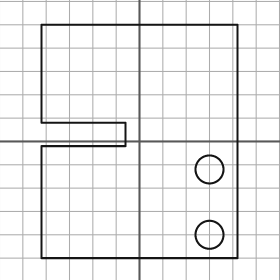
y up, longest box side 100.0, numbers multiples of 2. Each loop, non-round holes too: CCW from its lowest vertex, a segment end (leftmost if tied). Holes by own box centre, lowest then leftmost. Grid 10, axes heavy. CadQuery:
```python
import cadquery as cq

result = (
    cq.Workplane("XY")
    .moveTo(-42.0, -50.0)
    .lineTo(42.0, -50.0)
    .lineTo(42.0, 50.0)
    .lineTo(-42.0, 50.0)
    .lineTo(-42.0, 8.0)
    .lineTo(-6.0, 8.0)
    .lineTo(-6.0, -2.0)
    .lineTo(-42.0, -2.0)
    .close()
    .moveTo(30.0, -40.0)
    .circle(6.0)
    .moveTo(30.0, -12.0)
    .circle(6.0)
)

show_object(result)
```